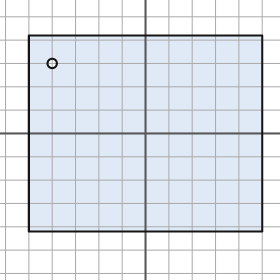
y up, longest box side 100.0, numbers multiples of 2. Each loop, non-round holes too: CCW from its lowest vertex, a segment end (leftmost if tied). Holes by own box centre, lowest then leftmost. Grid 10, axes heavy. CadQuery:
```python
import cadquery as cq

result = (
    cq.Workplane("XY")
    .moveTo(-50.0, -42.0)
    .lineTo(50.0, -42.0)
    .lineTo(50.0, 42.0)
    .lineTo(-50.0, 42.0)
    .close()
    .moveTo(-40.0, 30.0)
    .circle(2.0)
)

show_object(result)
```